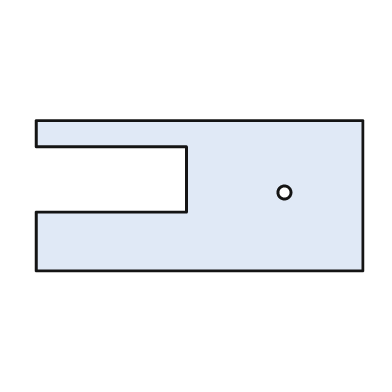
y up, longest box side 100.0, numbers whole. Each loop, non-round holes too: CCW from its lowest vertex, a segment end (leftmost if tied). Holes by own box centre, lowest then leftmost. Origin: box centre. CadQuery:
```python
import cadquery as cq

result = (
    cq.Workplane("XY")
    .moveTo(-50.0, -23.0)
    .lineTo(50.0, -23.0)
    .lineTo(50.0, 23.0)
    .lineTo(-50.0, 23.0)
    .lineTo(-50.0, 15.0)
    .lineTo(-4.0, 15.0)
    .lineTo(-4.0, -5.0)
    .lineTo(-50.0, -5.0)
    .close()
    .moveTo(26.0, 1.0)
    .circle(2.0)
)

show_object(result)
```